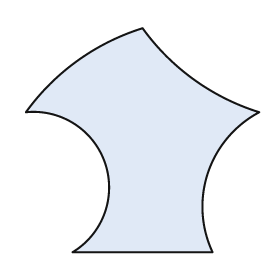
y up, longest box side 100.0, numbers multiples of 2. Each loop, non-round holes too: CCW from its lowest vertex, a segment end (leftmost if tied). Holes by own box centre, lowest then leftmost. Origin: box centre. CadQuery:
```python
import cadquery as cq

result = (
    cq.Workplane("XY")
    .moveTo(-30.0, -48.0)
    .lineTo(30.0, -48.0)
    .threePointArc((28.0, -14.0), (50.0, 12.0))
    .threePointArc((22.0, 26.0), (0.0, 48.0))
    .threePointArc((-28.0, 34.0), (-50.0, 12.0))
    .threePointArc((-16.0, -10.0), (-30.0, -48.0))
    .close()
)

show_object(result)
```